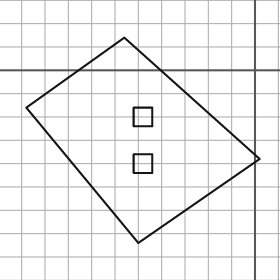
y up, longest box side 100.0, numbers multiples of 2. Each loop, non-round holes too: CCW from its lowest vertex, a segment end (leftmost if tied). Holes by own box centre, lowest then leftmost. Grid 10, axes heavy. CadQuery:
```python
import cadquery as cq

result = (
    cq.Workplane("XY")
    .moveTo(-50.0, -74.0)
    .lineTo(2.0, -38.0)
    .lineTo(-56.0, 14.0)
    .lineTo(-98.0, -16.0)
    .close()
    .moveTo(-52.0, -44.0)
    .lineTo(-44.0, -44.0)
    .lineTo(-44.0, -36.0)
    .lineTo(-52.0, -36.0)
    .close()
    .moveTo(-52.0, -24.0)
    .lineTo(-44.0, -24.0)
    .lineTo(-44.0, -16.0)
    .lineTo(-52.0, -16.0)
    .close()
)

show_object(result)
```